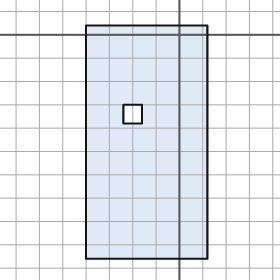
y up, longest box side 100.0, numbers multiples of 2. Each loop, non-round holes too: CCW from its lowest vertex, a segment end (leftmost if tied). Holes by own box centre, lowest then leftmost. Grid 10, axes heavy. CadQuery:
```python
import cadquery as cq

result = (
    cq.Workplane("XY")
    .moveTo(-40.0, -96.0)
    .lineTo(12.0, -96.0)
    .lineTo(12.0, 4.0)
    .lineTo(-40.0, 4.0)
    .close()
    .moveTo(-24.0, -38.0)
    .lineTo(-16.0, -38.0)
    .lineTo(-16.0, -30.0)
    .lineTo(-24.0, -30.0)
    .close()
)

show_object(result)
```